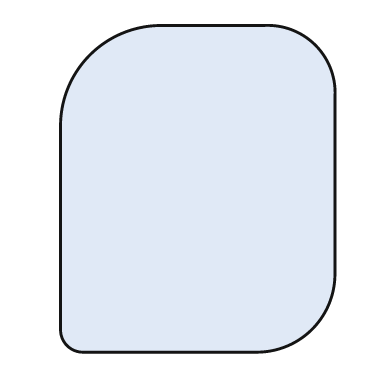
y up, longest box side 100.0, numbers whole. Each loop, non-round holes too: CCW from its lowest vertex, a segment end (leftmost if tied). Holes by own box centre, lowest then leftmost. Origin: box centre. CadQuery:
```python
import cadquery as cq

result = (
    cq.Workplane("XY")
    .moveTo(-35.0, -50.0)
    .lineTo(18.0, -50.0)
    .threePointArc((35.0, -43.0), (42.0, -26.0))
    .lineTo(42.0, 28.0)
    .threePointArc((36.0, 44.0), (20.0, 50.0))
    .lineTo(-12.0, 50.0)
    .threePointArc((-33.0, 41.0), (-42.0, 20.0))
    .lineTo(-42.0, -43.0)
    .threePointArc((-40.0, -48.0), (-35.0, -50.0))
    .close()
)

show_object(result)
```